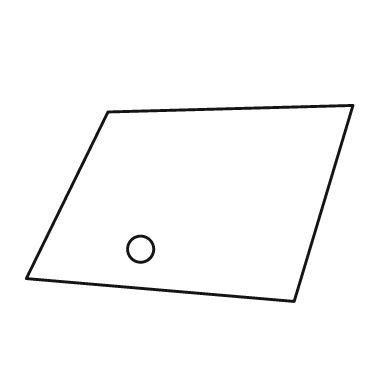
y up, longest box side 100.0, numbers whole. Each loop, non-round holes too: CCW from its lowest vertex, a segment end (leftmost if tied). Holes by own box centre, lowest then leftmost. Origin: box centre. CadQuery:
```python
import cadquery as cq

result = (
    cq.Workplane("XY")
    .moveTo(32.0, -30.0)
    .lineTo(50.0, 30.0)
    .lineTo(-25.0, 28.0)
    .lineTo(-50.0, -23.0)
    .close()
    .moveTo(-15.0, -14.0)
    .circle(4.0)
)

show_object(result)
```